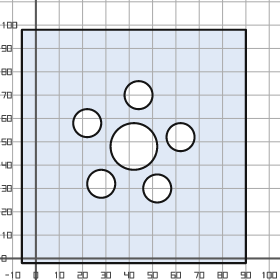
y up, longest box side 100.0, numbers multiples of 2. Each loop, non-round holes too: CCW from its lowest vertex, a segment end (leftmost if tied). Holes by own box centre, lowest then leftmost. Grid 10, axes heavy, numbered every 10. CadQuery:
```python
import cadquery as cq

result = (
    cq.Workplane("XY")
    .moveTo(-6.0, -2.0)
    .lineTo(90.0, -2.0)
    .lineTo(90.0, 98.0)
    .lineTo(-6.0, 98.0)
    .close()
    .moveTo(52.0, 30.0)
    .circle(6.0)
    .moveTo(28.0, 32.0)
    .circle(6.0)
    .moveTo(42.0, 48.0)
    .circle(10.0)
    .moveTo(62.0, 52.0)
    .circle(6.0)
    .moveTo(22.0, 58.0)
    .circle(6.0)
    .moveTo(44.0, 70.0)
    .circle(6.0)
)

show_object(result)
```